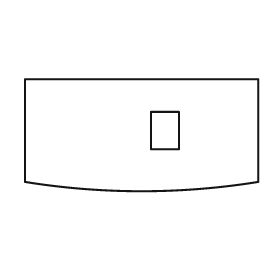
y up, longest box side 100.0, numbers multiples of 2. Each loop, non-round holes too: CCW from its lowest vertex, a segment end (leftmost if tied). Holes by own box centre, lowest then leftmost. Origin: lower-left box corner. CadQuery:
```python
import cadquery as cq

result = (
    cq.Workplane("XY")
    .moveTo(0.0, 4.0)
    .threePointArc((50.0, 0.0), (100.0, 4.0))
    .lineTo(100.0, 48.0)
    .lineTo(0.0, 48.0)
    .close()
    .moveTo(54.0, 18.0)
    .lineTo(66.0, 18.0)
    .lineTo(66.0, 34.0)
    .lineTo(54.0, 34.0)
    .close()
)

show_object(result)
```